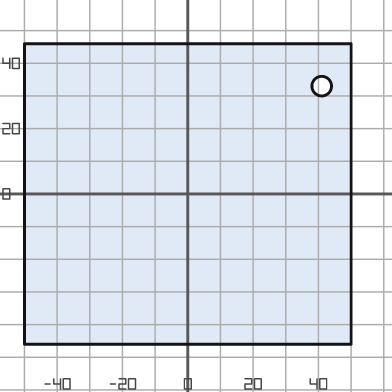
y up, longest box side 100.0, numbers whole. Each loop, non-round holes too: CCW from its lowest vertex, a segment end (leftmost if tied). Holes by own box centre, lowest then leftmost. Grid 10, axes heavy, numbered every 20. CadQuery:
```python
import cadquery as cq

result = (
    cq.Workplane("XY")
    .moveTo(-50.0, -46.0)
    .lineTo(50.0, -46.0)
    .lineTo(50.0, 46.0)
    .lineTo(-50.0, 46.0)
    .close()
    .moveTo(41.0, 33.0)
    .circle(3.0)
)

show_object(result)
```